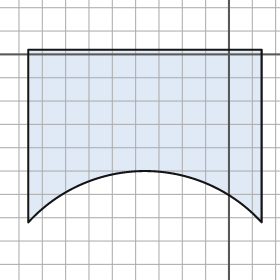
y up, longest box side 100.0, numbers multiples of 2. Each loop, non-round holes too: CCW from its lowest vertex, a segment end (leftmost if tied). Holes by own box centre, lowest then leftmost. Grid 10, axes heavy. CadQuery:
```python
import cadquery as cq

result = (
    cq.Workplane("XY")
    .moveTo(-86.0, -72.0)
    .threePointArc((-36.0, -50.0), (14.0, -72.0))
    .lineTo(14.0, 2.0)
    .lineTo(-86.0, 2.0)
    .close()
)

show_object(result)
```